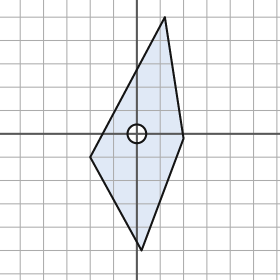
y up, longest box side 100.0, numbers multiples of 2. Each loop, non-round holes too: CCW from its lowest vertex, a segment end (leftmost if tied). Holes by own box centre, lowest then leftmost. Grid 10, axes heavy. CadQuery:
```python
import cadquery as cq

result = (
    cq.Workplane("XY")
    .moveTo(2.0, -50.0)
    .lineTo(20.0, -2.0)
    .lineTo(12.0, 50.0)
    .lineTo(-20.0, -10.0)
    .close()
    .moveTo(0.0, 0.0)
    .circle(4.0)
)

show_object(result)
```